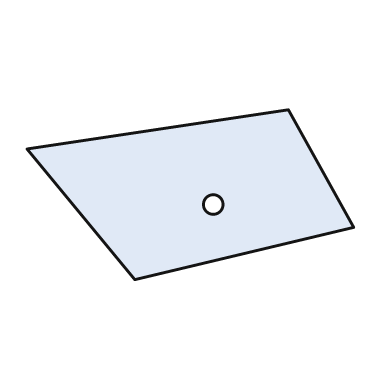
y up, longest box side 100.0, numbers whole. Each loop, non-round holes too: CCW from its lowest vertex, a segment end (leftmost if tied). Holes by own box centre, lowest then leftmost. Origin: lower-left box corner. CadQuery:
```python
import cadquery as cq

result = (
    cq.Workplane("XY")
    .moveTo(33.0, 0.0)
    .lineTo(100.0, 16.0)
    .lineTo(80.0, 52.0)
    .lineTo(0.0, 40.0)
    .close()
    .moveTo(57.0, 23.0)
    .circle(3.0)
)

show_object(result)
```